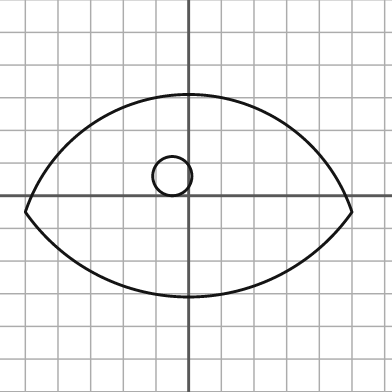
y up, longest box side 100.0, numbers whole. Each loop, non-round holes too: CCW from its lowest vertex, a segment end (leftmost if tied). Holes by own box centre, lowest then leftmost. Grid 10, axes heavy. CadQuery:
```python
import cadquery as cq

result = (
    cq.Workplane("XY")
    .moveTo(-50.0, -5.0)
    .threePointArc((0.0, -31.0), (50.0, -5.0))
    .threePointArc((0.0, 31.0), (-50.0, -5.0))
    .close()
    .moveTo(-5.0, 6.0)
    .circle(6.0)
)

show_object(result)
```